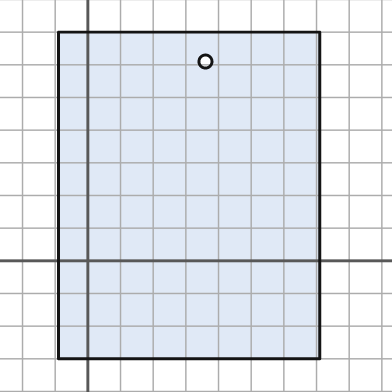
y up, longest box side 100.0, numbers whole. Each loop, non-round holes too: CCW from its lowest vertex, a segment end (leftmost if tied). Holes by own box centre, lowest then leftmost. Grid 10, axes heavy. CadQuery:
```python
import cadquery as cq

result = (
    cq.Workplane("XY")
    .moveTo(-9.0, -30.0)
    .lineTo(71.0, -30.0)
    .lineTo(71.0, 70.0)
    .lineTo(-9.0, 70.0)
    .close()
    .moveTo(36.0, 61.0)
    .circle(2.0)
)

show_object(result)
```